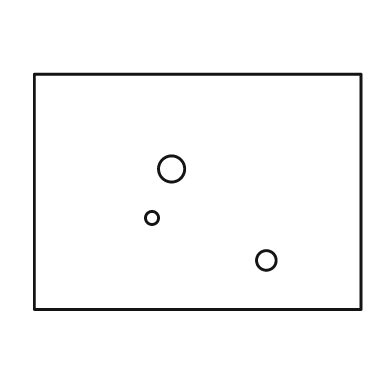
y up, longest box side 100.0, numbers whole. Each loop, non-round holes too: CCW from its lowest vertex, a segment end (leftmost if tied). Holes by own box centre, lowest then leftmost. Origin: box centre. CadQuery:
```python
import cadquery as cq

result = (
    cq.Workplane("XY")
    .moveTo(-50.0, -36.0)
    .lineTo(50.0, -36.0)
    .lineTo(50.0, 36.0)
    .lineTo(-50.0, 36.0)
    .close()
    .moveTo(21.0, -21.0)
    .circle(3.0)
    .moveTo(-14.0, -8.0)
    .circle(2.0)
    .moveTo(-8.0, 7.0)
    .circle(4.0)
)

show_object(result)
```